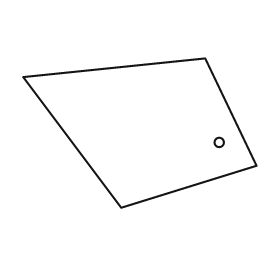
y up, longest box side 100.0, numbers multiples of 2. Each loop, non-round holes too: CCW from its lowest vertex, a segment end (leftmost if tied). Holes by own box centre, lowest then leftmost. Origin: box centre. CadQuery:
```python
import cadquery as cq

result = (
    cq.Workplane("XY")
    .moveTo(-8.0, -32.0)
    .lineTo(50.0, -14.0)
    .lineTo(28.0, 32.0)
    .lineTo(-50.0, 24.0)
    .close()
    .moveTo(34.0, -4.0)
    .circle(2.0)
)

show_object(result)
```